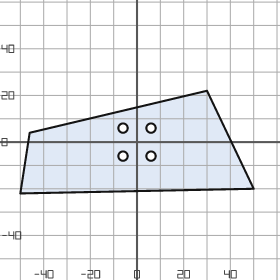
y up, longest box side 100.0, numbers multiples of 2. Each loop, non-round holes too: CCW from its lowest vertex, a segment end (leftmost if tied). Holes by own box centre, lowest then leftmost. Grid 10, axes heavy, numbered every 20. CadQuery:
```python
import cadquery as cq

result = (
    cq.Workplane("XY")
    .moveTo(-50.0, -22.0)
    .lineTo(50.0, -20.0)
    .lineTo(30.0, 22.0)
    .lineTo(-46.0, 4.0)
    .close()
    .moveTo(-6.0, -6.0)
    .circle(2.0)
    .moveTo(6.0, -6.0)
    .circle(2.0)
    .moveTo(-6.0, 6.0)
    .circle(2.0)
    .moveTo(6.0, 6.0)
    .circle(2.0)
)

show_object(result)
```